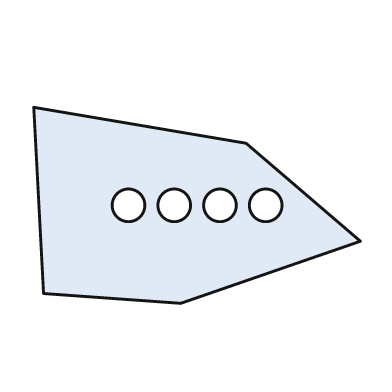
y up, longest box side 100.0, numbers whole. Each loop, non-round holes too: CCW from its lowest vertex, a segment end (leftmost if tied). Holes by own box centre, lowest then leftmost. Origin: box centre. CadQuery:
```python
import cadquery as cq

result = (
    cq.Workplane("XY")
    .moveTo(-5.0, -30.0)
    .lineTo(50.0, -11.0)
    .lineTo(15.0, 19.0)
    .lineTo(-50.0, 30.0)
    .lineTo(-47.0, -27.0)
    .close()
    .moveTo(-21.0, 0.0)
    .circle(5.0)
    .moveTo(-7.0, 0.0)
    .circle(5.0)
    .moveTo(7.0, 0.0)
    .circle(5.0)
    .moveTo(21.0, 0.0)
    .circle(5.0)
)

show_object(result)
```